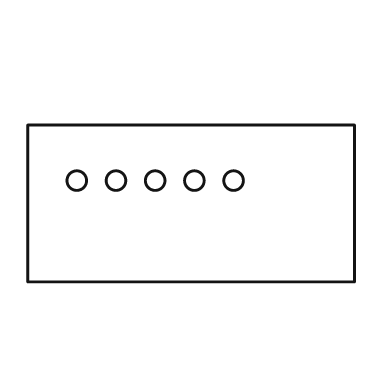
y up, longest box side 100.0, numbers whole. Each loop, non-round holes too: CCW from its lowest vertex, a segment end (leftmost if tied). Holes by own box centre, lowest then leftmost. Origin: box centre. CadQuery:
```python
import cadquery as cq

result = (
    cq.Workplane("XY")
    .moveTo(-50.0, -24.0)
    .lineTo(50.0, -24.0)
    .lineTo(50.0, 24.0)
    .lineTo(-50.0, 24.0)
    .close()
    .moveTo(-35.0, 7.0)
    .circle(3.0)
    .moveTo(-23.0, 7.0)
    .circle(3.0)
    .moveTo(-11.0, 7.0)
    .circle(3.0)
    .moveTo(1.0, 7.0)
    .circle(3.0)
    .moveTo(13.0, 7.0)
    .circle(3.0)
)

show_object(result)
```